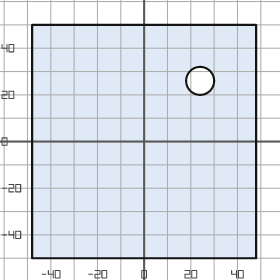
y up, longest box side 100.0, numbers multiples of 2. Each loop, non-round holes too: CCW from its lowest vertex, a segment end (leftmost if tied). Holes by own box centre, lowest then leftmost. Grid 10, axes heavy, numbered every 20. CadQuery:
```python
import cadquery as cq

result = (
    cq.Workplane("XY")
    .moveTo(-48.0, -50.0)
    .lineTo(48.0, -50.0)
    .lineTo(48.0, 50.0)
    .lineTo(-48.0, 50.0)
    .close()
    .moveTo(24.0, 26.0)
    .circle(6.0)
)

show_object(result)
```